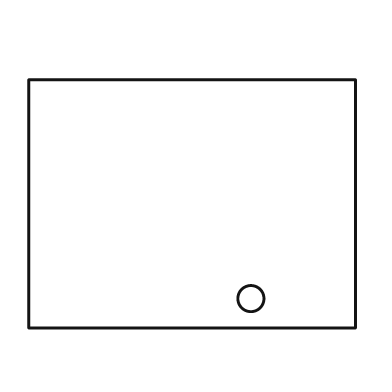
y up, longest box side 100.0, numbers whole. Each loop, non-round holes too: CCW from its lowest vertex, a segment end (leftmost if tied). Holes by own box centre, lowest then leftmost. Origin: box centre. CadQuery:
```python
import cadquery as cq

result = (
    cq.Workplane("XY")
    .moveTo(-50.0, -38.0)
    .lineTo(50.0, -38.0)
    .lineTo(50.0, 38.0)
    .lineTo(-50.0, 38.0)
    .close()
    .moveTo(18.0, -29.0)
    .circle(4.0)
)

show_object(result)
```